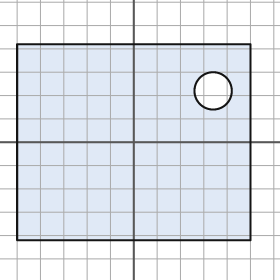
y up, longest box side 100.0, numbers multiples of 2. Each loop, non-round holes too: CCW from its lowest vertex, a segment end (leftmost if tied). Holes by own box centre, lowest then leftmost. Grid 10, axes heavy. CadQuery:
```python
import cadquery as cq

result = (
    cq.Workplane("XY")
    .moveTo(-50.0, -42.0)
    .lineTo(50.0, -42.0)
    .lineTo(50.0, 42.0)
    .lineTo(-50.0, 42.0)
    .close()
    .moveTo(34.0, 22.0)
    .circle(8.0)
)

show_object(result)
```